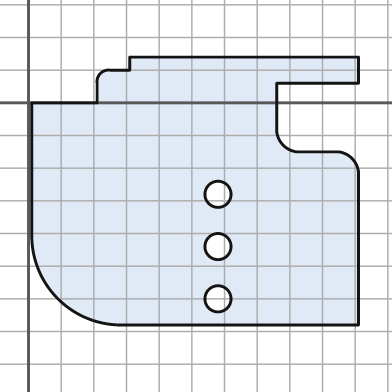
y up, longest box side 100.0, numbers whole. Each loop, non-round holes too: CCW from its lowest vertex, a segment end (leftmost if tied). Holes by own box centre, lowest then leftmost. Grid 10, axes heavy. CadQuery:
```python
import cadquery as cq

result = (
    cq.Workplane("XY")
    .moveTo(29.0, -68.0)
    .lineTo(101.0, -68.0)
    .lineTo(101.0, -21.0)
    .threePointArc((99.0, -17.0), (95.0, -15.0))
    .lineTo(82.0, -15.0)
    .threePointArc((78.0, -13.0), (76.0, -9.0))
    .lineTo(76.0, 6.0)
    .lineTo(101.0, 6.0)
    .lineTo(101.0, 14.0)
    .lineTo(31.0, 14.0)
    .lineTo(31.0, 10.0)
    .lineTo(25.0, 10.0)
    .threePointArc((22.0, 9.0), (21.0, 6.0))
    .lineTo(21.0, 0.0)
    .lineTo(1.0, 0.0)
    .lineTo(1.0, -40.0)
    .threePointArc((9.0, -60.0), (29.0, -68.0))
    .close()
    .moveTo(58.0, -60.0)
    .circle(4.0)
    .moveTo(58.0, -44.0)
    .circle(4.0)
    .moveTo(58.0, -28.0)
    .circle(4.0)
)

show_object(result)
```